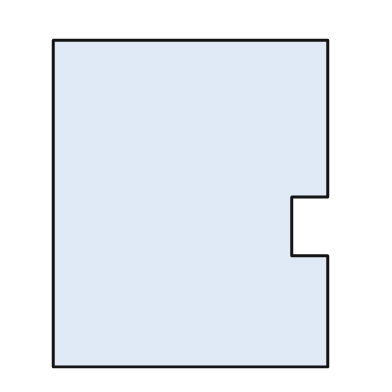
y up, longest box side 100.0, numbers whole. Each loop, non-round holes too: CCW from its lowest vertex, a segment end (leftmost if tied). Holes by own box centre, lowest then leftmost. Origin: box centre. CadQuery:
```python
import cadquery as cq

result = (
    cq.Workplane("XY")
    .moveTo(-42.0, -50.0)
    .lineTo(42.0, -50.0)
    .lineTo(42.0, -16.0)
    .lineTo(31.0, -16.0)
    .lineTo(31.0, 2.0)
    .lineTo(42.0, 2.0)
    .lineTo(42.0, 50.0)
    .lineTo(-42.0, 50.0)
    .close()
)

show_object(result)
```